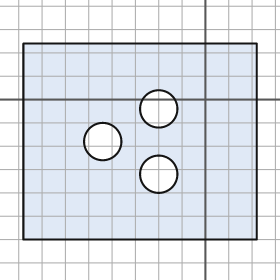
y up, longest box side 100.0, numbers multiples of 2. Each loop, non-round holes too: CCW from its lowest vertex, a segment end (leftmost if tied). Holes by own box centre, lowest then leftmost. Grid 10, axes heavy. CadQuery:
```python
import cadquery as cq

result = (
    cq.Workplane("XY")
    .moveTo(-78.0, -60.0)
    .lineTo(22.0, -60.0)
    .lineTo(22.0, 24.0)
    .lineTo(-78.0, 24.0)
    .close()
    .moveTo(-20.0, -32.0)
    .circle(8.0)
    .moveTo(-44.0, -18.0)
    .circle(8.0)
    .moveTo(-20.0, -4.0)
    .circle(8.0)
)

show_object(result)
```